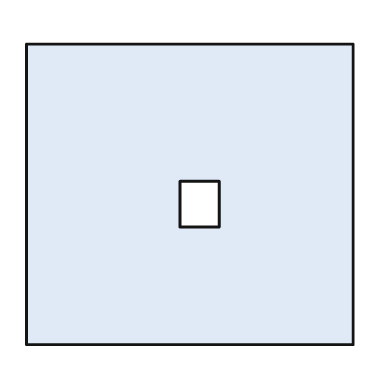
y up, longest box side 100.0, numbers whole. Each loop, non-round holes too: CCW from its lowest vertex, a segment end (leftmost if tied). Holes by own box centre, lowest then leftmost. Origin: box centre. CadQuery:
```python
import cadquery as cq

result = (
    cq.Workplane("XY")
    .moveTo(-50.0, -46.0)
    .lineTo(50.0, -46.0)
    .lineTo(50.0, 46.0)
    .lineTo(-50.0, 46.0)
    .close()
    .moveTo(-3.0, -10.0)
    .lineTo(9.0, -10.0)
    .lineTo(9.0, 4.0)
    .lineTo(-3.0, 4.0)
    .close()
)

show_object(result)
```